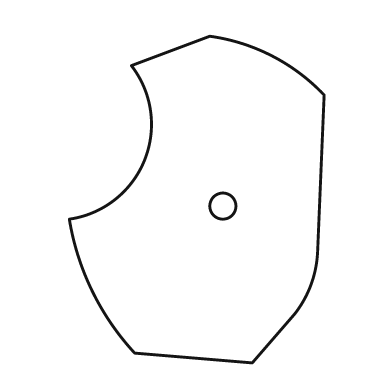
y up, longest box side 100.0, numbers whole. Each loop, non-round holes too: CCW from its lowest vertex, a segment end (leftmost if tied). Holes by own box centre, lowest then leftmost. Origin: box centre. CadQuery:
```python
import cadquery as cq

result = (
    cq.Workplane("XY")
    .moveTo(17.0, -50.0)
    .lineTo(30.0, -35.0)
    .threePointArc((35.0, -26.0), (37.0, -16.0))
    .lineTo(39.0, 32.0)
    .threePointArc((23.0, 44.0), (4.0, 50.0))
    .lineTo(-20.0, 41.0)
    .threePointArc((-16.0, 12.0), (-39.0, -6.0))
    .threePointArc((-32.0, -28.0), (-19.0, -47.0))
    .close()
    .moveTo(8.0, -2.0)
    .circle(4.0)
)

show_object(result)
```